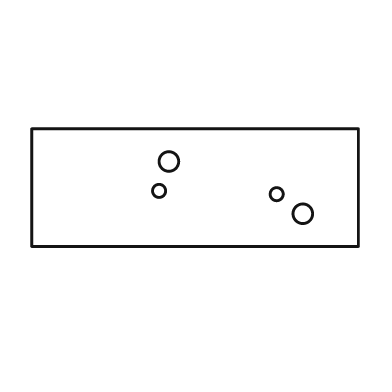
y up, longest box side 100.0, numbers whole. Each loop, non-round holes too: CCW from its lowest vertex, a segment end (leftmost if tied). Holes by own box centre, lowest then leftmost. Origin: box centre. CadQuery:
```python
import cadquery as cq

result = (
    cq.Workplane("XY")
    .moveTo(-50.0, -18.0)
    .lineTo(50.0, -18.0)
    .lineTo(50.0, 18.0)
    .lineTo(-50.0, 18.0)
    .close()
    .moveTo(33.0, -8.0)
    .circle(3.0)
    .moveTo(25.0, -2.0)
    .circle(2.0)
    .moveTo(-11.0, -1.0)
    .circle(2.0)
    .moveTo(-8.0, 8.0)
    .circle(3.0)
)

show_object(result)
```